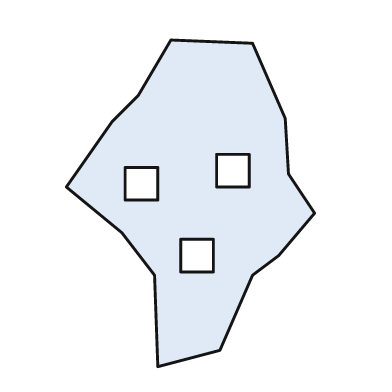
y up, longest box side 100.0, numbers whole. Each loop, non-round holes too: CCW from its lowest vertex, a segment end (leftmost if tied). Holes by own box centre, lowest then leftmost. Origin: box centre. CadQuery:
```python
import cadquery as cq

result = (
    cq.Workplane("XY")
    .moveTo(-10.0, -50.0)
    .lineTo(9.0, -45.0)
    .lineTo(19.0, -22.0)
    .lineTo(27.0, -16.0)
    .lineTo(38.0, -3.0)
    .lineTo(30.0, 9.0)
    .lineTo(29.0, 26.0)
    .lineTo(19.0, 49.0)
    .lineTo(-6.0, 50.0)
    .lineTo(-16.0, 33.0)
    .lineTo(-24.0, 25.0)
    .lineTo(-38.0, 5.0)
    .lineTo(-21.0, -9.0)
    .lineTo(-11.0, -22.0)
    .close()
    .moveTo(-3.0, -21.0)
    .lineTo(7.0, -21.0)
    .lineTo(7.0, -11.0)
    .lineTo(-3.0, -11.0)
    .close()
    .moveTo(-20.0, 1.0)
    .lineTo(-10.0, 1.0)
    .lineTo(-10.0, 11.0)
    .lineTo(-20.0, 11.0)
    .close()
    .moveTo(8.0, 5.0)
    .lineTo(18.0, 5.0)
    .lineTo(18.0, 15.0)
    .lineTo(8.0, 15.0)
    .close()
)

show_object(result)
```